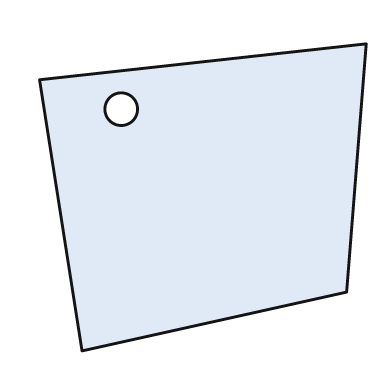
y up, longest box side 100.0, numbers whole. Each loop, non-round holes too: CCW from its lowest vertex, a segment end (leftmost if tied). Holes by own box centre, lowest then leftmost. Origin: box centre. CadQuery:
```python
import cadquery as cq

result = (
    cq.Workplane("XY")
    .moveTo(-37.0, -47.0)
    .lineTo(44.0, -29.0)
    .lineTo(50.0, 47.0)
    .lineTo(-50.0, 36.0)
    .close()
    .moveTo(-25.0, 27.0)
    .circle(5.0)
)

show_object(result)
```